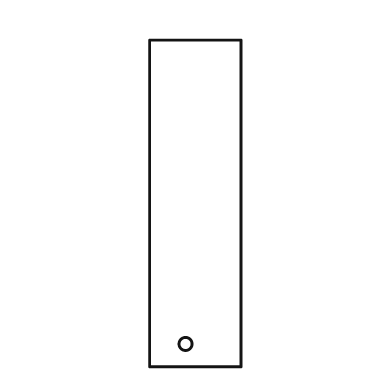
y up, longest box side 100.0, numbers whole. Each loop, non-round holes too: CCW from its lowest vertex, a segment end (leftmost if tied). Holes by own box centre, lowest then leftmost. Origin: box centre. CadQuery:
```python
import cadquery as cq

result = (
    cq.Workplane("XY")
    .moveTo(-14.0, -50.0)
    .lineTo(14.0, -50.0)
    .lineTo(14.0, 50.0)
    .lineTo(-14.0, 50.0)
    .close()
    .moveTo(-3.0, -43.0)
    .circle(2.0)
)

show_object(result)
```